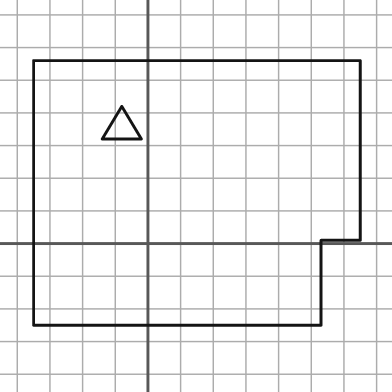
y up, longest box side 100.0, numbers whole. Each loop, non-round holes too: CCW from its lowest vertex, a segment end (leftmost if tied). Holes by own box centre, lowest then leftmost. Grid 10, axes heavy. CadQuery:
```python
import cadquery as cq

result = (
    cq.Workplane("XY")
    .moveTo(-35.0, -25.0)
    .lineTo(53.0, -25.0)
    .lineTo(53.0, 1.0)
    .lineTo(65.0, 1.0)
    .lineTo(65.0, 56.0)
    .lineTo(-35.0, 56.0)
    .close()
    .moveTo(-14.0, 32.0)
    .lineTo(-2.0, 32.0)
    .lineTo(-8.0, 42.0)
    .close()
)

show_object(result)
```